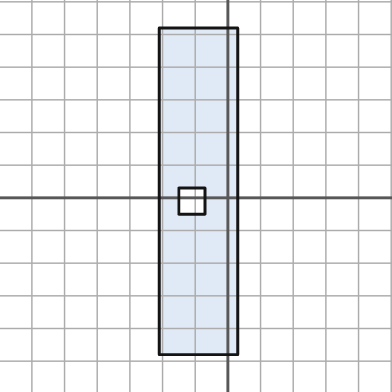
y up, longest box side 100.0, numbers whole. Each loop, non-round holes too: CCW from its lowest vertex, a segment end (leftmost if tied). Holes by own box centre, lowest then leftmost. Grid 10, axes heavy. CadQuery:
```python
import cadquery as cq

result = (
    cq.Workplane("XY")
    .moveTo(-21.0, -48.0)
    .lineTo(3.0, -48.0)
    .lineTo(3.0, 52.0)
    .lineTo(-21.0, 52.0)
    .close()
    .moveTo(-15.0, -5.0)
    .lineTo(-7.0, -5.0)
    .lineTo(-7.0, 3.0)
    .lineTo(-15.0, 3.0)
    .close()
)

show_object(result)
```